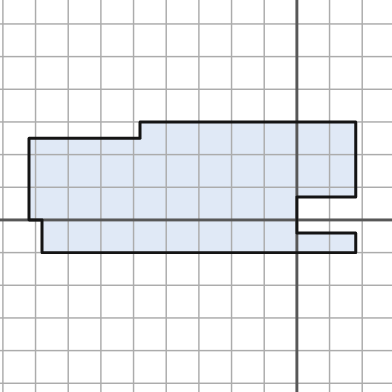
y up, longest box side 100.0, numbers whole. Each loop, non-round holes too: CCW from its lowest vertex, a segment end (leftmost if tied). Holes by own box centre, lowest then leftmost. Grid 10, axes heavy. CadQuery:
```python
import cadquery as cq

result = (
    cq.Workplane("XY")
    .moveTo(-78.0, -10.0)
    .lineTo(18.0, -10.0)
    .lineTo(18.0, -4.0)
    .lineTo(0.0, -4.0)
    .lineTo(0.0, 7.0)
    .lineTo(18.0, 7.0)
    .lineTo(18.0, 30.0)
    .lineTo(-48.0, 30.0)
    .lineTo(-48.0, 25.0)
    .lineTo(-82.0, 25.0)
    .lineTo(-82.0, 0.0)
    .lineTo(-78.0, 0.0)
    .close()
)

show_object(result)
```